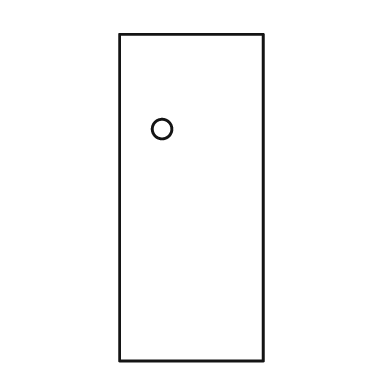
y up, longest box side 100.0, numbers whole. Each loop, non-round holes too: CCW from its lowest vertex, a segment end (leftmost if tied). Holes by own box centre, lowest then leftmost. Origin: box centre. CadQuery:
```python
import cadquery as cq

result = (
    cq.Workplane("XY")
    .moveTo(-22.0, -50.0)
    .lineTo(22.0, -50.0)
    .lineTo(22.0, 50.0)
    .lineTo(-22.0, 50.0)
    .close()
    .moveTo(-9.0, 21.0)
    .circle(3.0)
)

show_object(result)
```